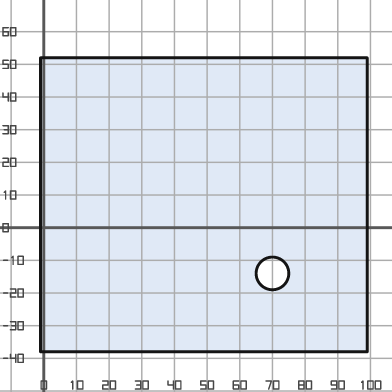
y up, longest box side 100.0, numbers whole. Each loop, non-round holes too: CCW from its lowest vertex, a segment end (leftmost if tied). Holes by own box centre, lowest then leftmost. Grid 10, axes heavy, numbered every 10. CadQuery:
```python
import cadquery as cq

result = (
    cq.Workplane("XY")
    .moveTo(-1.0, -38.0)
    .lineTo(99.0, -38.0)
    .lineTo(99.0, 52.0)
    .lineTo(-1.0, 52.0)
    .close()
    .moveTo(70.0, -14.0)
    .circle(5.0)
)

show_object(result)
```